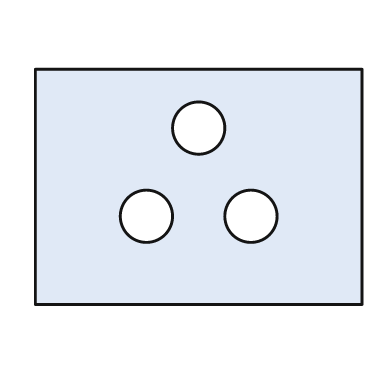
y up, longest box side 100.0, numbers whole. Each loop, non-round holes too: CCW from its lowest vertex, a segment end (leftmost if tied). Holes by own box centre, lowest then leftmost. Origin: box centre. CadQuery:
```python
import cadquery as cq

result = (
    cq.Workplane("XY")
    .moveTo(-50.0, -36.0)
    .lineTo(50.0, -36.0)
    .lineTo(50.0, 36.0)
    .lineTo(-50.0, 36.0)
    .close()
    .moveTo(-16.0, -9.0)
    .circle(8.0)
    .moveTo(16.0, -9.0)
    .circle(8.0)
    .moveTo(0.0, 18.0)
    .circle(8.0)
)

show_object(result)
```